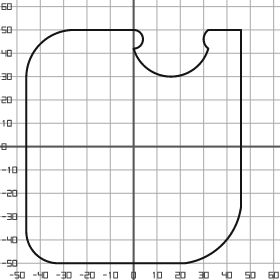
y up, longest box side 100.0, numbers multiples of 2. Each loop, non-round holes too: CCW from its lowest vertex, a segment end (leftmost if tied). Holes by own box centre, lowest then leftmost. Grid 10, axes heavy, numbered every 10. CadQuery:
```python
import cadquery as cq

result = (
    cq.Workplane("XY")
    .moveTo(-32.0, -50.0)
    .lineTo(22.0, -50.0)
    .threePointArc((38.0, -42.0), (46.0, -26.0))
    .lineTo(46.0, 50.0)
    .lineTo(32.0, 50.0)
    .threePointArc((30.0, 46.0), (32.0, 42.0))
    .threePointArc((16.0, 30.0), (0.0, 42.0))
    .threePointArc((4.0, 46.0), (0.0, 50.0))
    .lineTo(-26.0, 50.0)
    .threePointArc((-40.0, 44.0), (-46.0, 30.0))
    .lineTo(-46.0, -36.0)
    .threePointArc((-42.0, -46.0), (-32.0, -50.0))
    .close()
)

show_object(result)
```